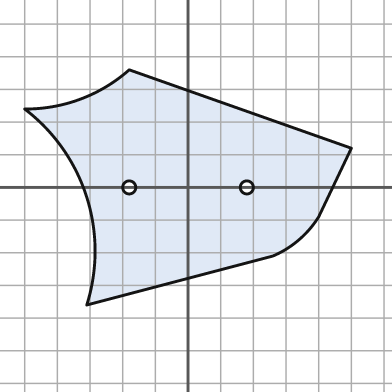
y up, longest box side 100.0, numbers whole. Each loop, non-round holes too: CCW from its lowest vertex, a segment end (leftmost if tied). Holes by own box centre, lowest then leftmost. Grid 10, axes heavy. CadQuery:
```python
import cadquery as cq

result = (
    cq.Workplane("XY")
    .moveTo(-31.0, -36.0)
    .lineTo(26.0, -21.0)
    .threePointArc((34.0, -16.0), (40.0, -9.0))
    .lineTo(50.0, 12.0)
    .lineTo(-18.0, 36.0)
    .threePointArc((-33.0, 27.0), (-50.0, 24.0))
    .threePointArc((-31.0, -3.0), (-31.0, -36.0))
    .close()
    .moveTo(-18.0, 0.0)
    .circle(2.0)
    .moveTo(18.0, 0.0)
    .circle(2.0)
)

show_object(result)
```